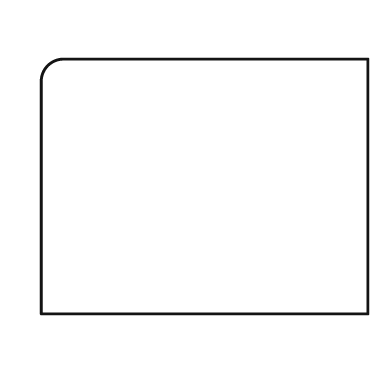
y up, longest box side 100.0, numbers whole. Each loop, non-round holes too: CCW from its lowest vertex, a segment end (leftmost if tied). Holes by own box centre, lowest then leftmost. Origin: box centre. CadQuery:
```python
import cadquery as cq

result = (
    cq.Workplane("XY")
    .moveTo(-50.0, -39.0)
    .lineTo(50.0, -39.0)
    .lineTo(50.0, 39.0)
    .lineTo(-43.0, 39.0)
    .threePointArc((-48.0, 37.0), (-50.0, 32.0))
    .close()
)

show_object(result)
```